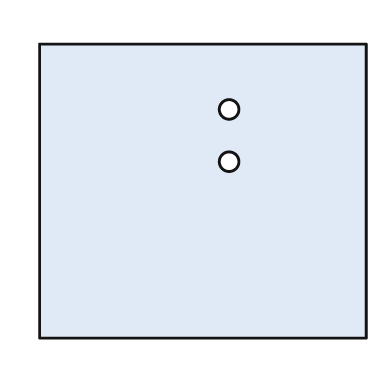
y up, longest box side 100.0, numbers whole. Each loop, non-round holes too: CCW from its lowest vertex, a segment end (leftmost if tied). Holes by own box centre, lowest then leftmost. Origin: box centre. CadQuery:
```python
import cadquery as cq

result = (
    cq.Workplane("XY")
    .moveTo(-50.0, -45.0)
    .lineTo(50.0, -45.0)
    .lineTo(50.0, 45.0)
    .lineTo(-50.0, 45.0)
    .close()
    .moveTo(8.0, 9.0)
    .circle(3.0)
    .moveTo(8.0, 25.0)
    .circle(3.0)
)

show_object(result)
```